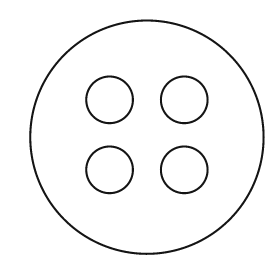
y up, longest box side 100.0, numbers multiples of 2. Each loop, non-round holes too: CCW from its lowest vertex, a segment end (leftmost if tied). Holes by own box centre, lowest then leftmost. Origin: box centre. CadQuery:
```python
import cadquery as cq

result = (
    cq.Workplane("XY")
    .moveTo(0.0, 0.0)
    .circle(50.0)
    .moveTo(-16.0, -14.0)
    .circle(10.0)
    .moveTo(16.0, -14.0)
    .circle(10.0)
    .moveTo(-16.0, 16.0)
    .circle(10.0)
    .moveTo(16.0, 16.0)
    .circle(10.0)
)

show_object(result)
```